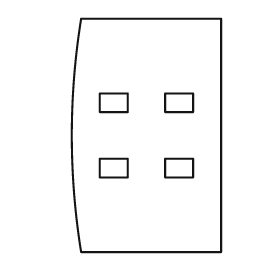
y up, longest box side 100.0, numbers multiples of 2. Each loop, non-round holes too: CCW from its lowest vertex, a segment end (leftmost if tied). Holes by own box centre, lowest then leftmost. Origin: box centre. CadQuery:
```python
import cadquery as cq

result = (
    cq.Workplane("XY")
    .moveTo(-28.0, -50.0)
    .lineTo(32.0, -50.0)
    .lineTo(32.0, 50.0)
    .lineTo(-28.0, 50.0)
    .threePointArc((-32.0, 0.0), (-28.0, -50.0))
    .close()
    .moveTo(-20.0, -18.0)
    .lineTo(-8.0, -18.0)
    .lineTo(-8.0, -10.0)
    .lineTo(-20.0, -10.0)
    .close()
    .moveTo(8.0, -18.0)
    .lineTo(20.0, -18.0)
    .lineTo(20.0, -10.0)
    .lineTo(8.0, -10.0)
    .close()
    .moveTo(-20.0, 10.0)
    .lineTo(-8.0, 10.0)
    .lineTo(-8.0, 18.0)
    .lineTo(-20.0, 18.0)
    .close()
    .moveTo(8.0, 10.0)
    .lineTo(20.0, 10.0)
    .lineTo(20.0, 18.0)
    .lineTo(8.0, 18.0)
    .close()
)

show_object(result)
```